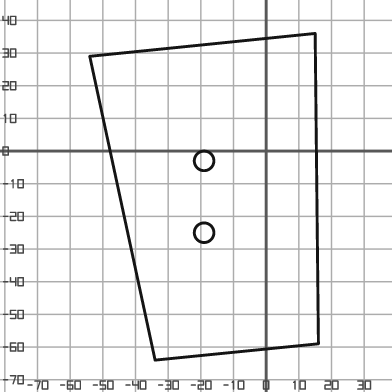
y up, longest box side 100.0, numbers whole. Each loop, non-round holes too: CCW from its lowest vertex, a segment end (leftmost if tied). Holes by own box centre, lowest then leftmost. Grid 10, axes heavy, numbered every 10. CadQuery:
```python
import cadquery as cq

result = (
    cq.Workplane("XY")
    .moveTo(-34.0, -64.0)
    .lineTo(16.0, -59.0)
    .lineTo(15.0, 36.0)
    .lineTo(-54.0, 29.0)
    .close()
    .moveTo(-19.0, -25.0)
    .circle(3.0)
    .moveTo(-19.0, -3.0)
    .circle(3.0)
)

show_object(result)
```